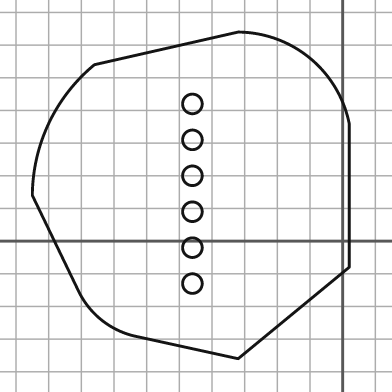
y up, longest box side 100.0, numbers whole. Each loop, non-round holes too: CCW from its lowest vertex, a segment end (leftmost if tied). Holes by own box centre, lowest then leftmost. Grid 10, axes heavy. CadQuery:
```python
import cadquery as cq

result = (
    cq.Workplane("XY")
    .moveTo(-32.0, -36.0)
    .lineTo(2.0, -8.0)
    .lineTo(2.0, 36.0)
    .threePointArc((-10.0, 56.0), (-32.0, 64.0))
    .lineTo(-76.0, 54.0)
    .threePointArc((-90.0, 36.0), (-95.0, 14.0))
    .lineTo(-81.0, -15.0)
    .threePointArc((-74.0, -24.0), (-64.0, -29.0))
    .close()
    .moveTo(-46.0, -13.0)
    .circle(3.0)
    .moveTo(-46.0, -2.0)
    .circle(3.0)
    .moveTo(-46.0, 9.0)
    .circle(3.0)
    .moveTo(-46.0, 20.0)
    .circle(3.0)
    .moveTo(-46.0, 31.0)
    .circle(3.0)
    .moveTo(-46.0, 42.0)
    .circle(3.0)
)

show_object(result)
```